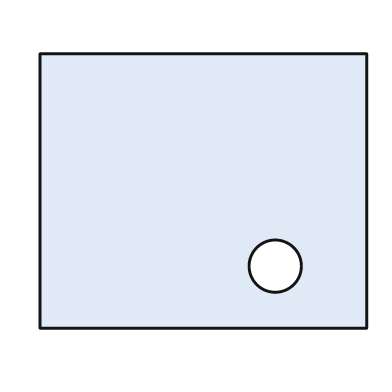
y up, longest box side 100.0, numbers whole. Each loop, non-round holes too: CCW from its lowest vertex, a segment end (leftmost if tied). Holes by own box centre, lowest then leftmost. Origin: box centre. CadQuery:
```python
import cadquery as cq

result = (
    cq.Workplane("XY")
    .moveTo(-50.0, -42.0)
    .lineTo(50.0, -42.0)
    .lineTo(50.0, 42.0)
    .lineTo(-50.0, 42.0)
    .close()
    .moveTo(22.0, -23.0)
    .circle(8.0)
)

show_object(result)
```